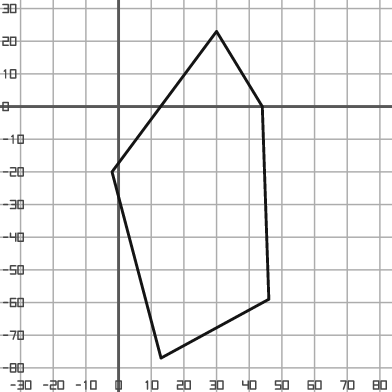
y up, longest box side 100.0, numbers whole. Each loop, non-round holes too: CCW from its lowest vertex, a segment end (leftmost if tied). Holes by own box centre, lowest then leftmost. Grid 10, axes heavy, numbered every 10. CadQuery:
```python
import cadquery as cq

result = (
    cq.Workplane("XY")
    .moveTo(13.0, -77.0)
    .lineTo(46.0, -59.0)
    .lineTo(44.0, 0.0)
    .lineTo(30.0, 23.0)
    .lineTo(-2.0, -20.0)
    .close()
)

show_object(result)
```